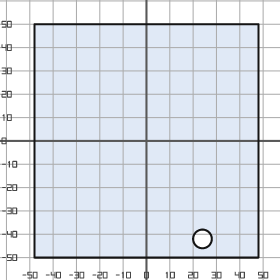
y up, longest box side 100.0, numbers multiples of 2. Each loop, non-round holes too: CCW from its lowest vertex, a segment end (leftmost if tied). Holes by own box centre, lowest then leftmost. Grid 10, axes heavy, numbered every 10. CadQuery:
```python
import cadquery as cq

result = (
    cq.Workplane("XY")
    .moveTo(-48.0, -50.0)
    .lineTo(48.0, -50.0)
    .lineTo(48.0, 50.0)
    .lineTo(-48.0, 50.0)
    .close()
    .moveTo(24.0, -42.0)
    .circle(4.0)
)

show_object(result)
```